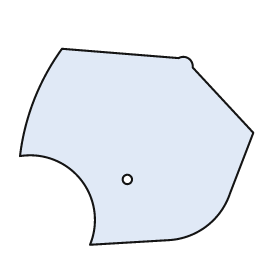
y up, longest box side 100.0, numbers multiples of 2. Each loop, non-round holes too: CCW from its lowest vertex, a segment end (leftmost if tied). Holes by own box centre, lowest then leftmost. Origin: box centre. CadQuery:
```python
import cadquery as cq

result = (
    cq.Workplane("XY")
    .moveTo(-20.0, -42.0)
    .lineTo(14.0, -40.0)
    .threePointArc((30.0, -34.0), (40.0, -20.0))
    .lineTo(50.0, 6.0)
    .lineTo(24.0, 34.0)
    .threePointArc((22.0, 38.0), (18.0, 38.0))
    .lineTo(-32.0, 42.0)
    .threePointArc((-44.0, 20.0), (-50.0, -4.0))
    .threePointArc((-24.0, -14.0), (-20.0, -42.0))
    .close()
    .moveTo(-4.0, -14.0)
    .circle(2.0)
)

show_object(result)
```